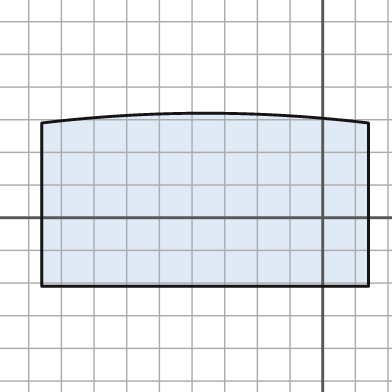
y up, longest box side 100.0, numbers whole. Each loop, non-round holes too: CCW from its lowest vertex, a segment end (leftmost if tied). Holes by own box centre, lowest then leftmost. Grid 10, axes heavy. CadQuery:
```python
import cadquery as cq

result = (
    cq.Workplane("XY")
    .moveTo(-86.0, -21.0)
    .lineTo(14.0, -21.0)
    .lineTo(14.0, 29.0)
    .threePointArc((-36.0, 32.0), (-86.0, 29.0))
    .close()
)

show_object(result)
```